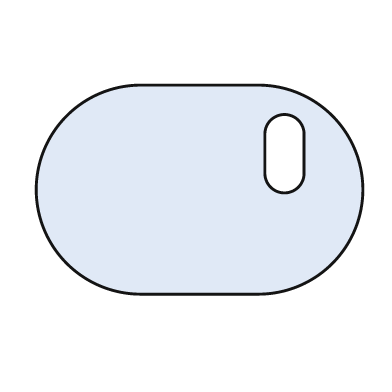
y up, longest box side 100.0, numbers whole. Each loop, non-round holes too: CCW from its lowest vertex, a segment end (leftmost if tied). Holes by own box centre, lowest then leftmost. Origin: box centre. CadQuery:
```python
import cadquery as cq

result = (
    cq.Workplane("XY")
    .moveTo(-18.0, -32.0)
    .lineTo(18.0, -32.0)
    .threePointArc((50.0, 0.0), (18.0, 32.0))
    .lineTo(-18.0, 32.0)
    .threePointArc((-50.0, 0.0), (-18.0, -32.0))
    .close()
    .moveTo(20.0, 5.0)
    .threePointArc((26.0, -1.0), (32.0, 5.0))
    .lineTo(32.0, 17.0)
    .threePointArc((26.0, 23.0), (20.0, 17.0))
    .close()
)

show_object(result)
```